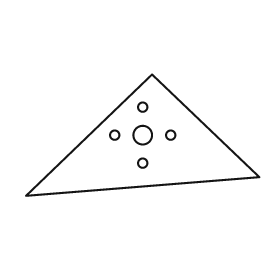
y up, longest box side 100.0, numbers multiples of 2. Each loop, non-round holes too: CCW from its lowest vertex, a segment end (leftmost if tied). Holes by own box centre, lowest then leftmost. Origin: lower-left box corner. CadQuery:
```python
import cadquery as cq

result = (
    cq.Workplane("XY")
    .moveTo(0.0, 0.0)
    .lineTo(100.0, 8.0)
    .lineTo(54.0, 52.0)
    .close()
    .moveTo(50.0, 14.0)
    .circle(2.0)
    .moveTo(38.0, 26.0)
    .circle(2.0)
    .moveTo(50.0, 26.0)
    .circle(4.0)
    .moveTo(62.0, 26.0)
    .circle(2.0)
    .moveTo(50.0, 38.0)
    .circle(2.0)
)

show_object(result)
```